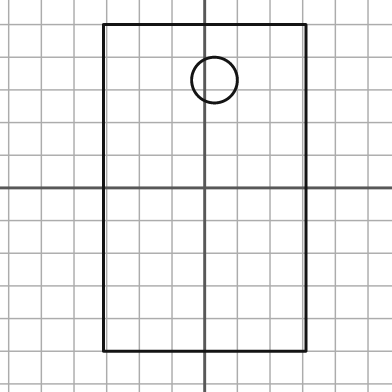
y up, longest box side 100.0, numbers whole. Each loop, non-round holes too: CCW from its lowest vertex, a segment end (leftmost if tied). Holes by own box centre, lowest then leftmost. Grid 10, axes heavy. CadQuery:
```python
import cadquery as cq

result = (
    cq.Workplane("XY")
    .moveTo(-31.0, -50.0)
    .lineTo(31.0, -50.0)
    .lineTo(31.0, 50.0)
    .lineTo(-31.0, 50.0)
    .close()
    .moveTo(3.0, 33.0)
    .circle(7.0)
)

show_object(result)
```